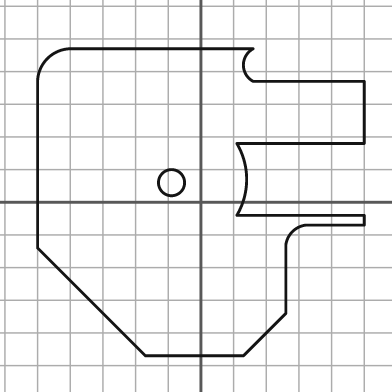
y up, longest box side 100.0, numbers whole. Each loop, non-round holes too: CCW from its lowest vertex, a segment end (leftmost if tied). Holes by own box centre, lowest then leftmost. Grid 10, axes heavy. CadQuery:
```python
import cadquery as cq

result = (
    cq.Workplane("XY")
    .moveTo(-17.0, -47.0)
    .lineTo(13.0, -47.0)
    .lineTo(26.0, -34.0)
    .lineTo(26.0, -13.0)
    .threePointArc((28.0, -9.0), (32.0, -7.0))
    .lineTo(50.0, -7.0)
    .lineTo(50.0, -4.0)
    .lineTo(11.0, -4.0)
    .threePointArc((14.0, 7.0), (11.0, 18.0))
    .lineTo(50.0, 18.0)
    .lineTo(50.0, 37.0)
    .lineTo(16.0, 37.0)
    .threePointArc((13.0, 42.0), (16.0, 47.0))
    .lineTo(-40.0, 47.0)
    .threePointArc((-47.0, 44.0), (-50.0, 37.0))
    .lineTo(-50.0, -14.0)
    .close()
    .moveTo(-9.0, 6.0)
    .circle(4.0)
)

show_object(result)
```